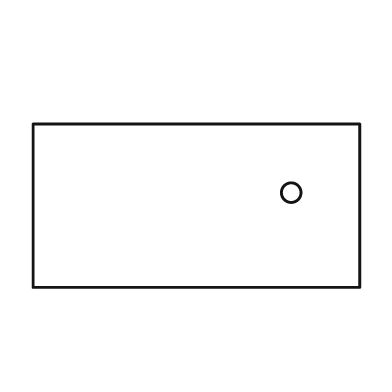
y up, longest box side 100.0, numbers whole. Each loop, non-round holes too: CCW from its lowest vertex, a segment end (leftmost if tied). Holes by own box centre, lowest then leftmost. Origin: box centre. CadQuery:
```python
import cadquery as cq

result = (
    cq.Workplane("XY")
    .moveTo(-50.0, -25.0)
    .lineTo(50.0, -25.0)
    .lineTo(50.0, 25.0)
    .lineTo(-50.0, 25.0)
    .close()
    .moveTo(29.0, 4.0)
    .circle(3.0)
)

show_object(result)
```